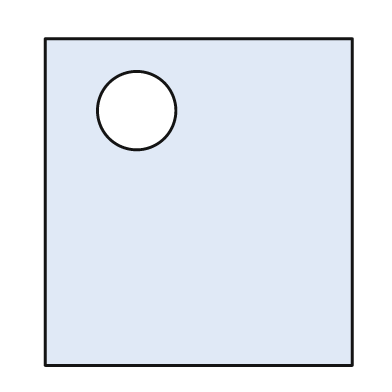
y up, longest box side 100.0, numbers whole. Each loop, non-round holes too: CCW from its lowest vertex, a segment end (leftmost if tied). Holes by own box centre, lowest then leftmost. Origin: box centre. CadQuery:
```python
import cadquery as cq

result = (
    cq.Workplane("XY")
    .moveTo(-47.0, -50.0)
    .lineTo(47.0, -50.0)
    .lineTo(47.0, 50.0)
    .lineTo(-47.0, 50.0)
    .close()
    .moveTo(-19.0, 28.0)
    .circle(12.0)
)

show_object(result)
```